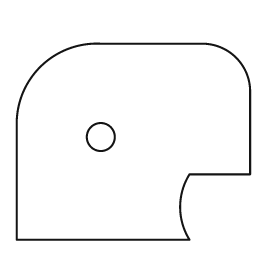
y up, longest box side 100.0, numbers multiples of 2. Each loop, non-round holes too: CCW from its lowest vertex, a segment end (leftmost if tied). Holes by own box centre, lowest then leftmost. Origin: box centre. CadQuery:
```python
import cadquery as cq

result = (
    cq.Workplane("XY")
    .moveTo(-50.0, -42.0)
    .lineTo(24.0, -42.0)
    .threePointArc((20.0, -28.0), (24.0, -14.0))
    .lineTo(50.0, -14.0)
    .lineTo(50.0, 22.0)
    .threePointArc((44.0, 36.0), (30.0, 42.0))
    .lineTo(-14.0, 42.0)
    .threePointArc((-40.0, 32.0), (-50.0, 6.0))
    .close()
    .moveTo(-14.0, 2.0)
    .circle(6.0)
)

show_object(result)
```